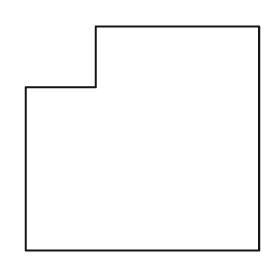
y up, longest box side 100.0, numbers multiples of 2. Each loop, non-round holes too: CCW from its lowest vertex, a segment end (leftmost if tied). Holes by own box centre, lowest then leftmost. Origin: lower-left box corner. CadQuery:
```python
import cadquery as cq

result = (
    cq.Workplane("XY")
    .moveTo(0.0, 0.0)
    .lineTo(100.0, 0.0)
    .lineTo(100.0, 96.0)
    .lineTo(30.0, 96.0)
    .lineTo(30.0, 70.0)
    .lineTo(0.0, 70.0)
    .close()
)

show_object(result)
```